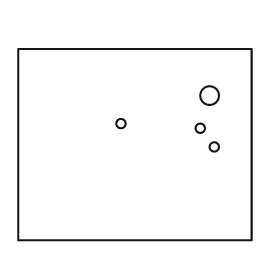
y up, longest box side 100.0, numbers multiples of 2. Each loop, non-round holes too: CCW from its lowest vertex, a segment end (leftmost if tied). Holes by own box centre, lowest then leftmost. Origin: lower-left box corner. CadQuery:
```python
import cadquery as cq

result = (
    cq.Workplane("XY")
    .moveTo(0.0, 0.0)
    .lineTo(100.0, 0.0)
    .lineTo(100.0, 82.0)
    .lineTo(0.0, 82.0)
    .close()
    .moveTo(84.0, 40.0)
    .circle(2.0)
    .moveTo(78.0, 48.0)
    .circle(2.0)
    .moveTo(44.0, 50.0)
    .circle(2.0)
    .moveTo(82.0, 62.0)
    .circle(4.0)
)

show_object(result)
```